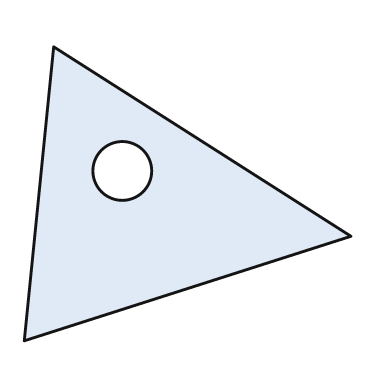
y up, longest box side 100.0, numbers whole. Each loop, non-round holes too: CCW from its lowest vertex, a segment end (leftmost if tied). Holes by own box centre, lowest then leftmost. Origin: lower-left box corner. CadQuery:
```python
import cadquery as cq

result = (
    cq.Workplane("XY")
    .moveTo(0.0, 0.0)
    .lineTo(100.0, 32.0)
    .lineTo(9.0, 90.0)
    .close()
    .moveTo(30.0, 52.0)
    .circle(9.0)
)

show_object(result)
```